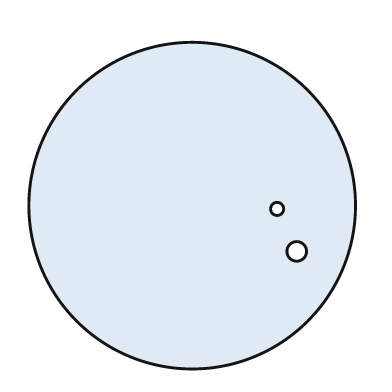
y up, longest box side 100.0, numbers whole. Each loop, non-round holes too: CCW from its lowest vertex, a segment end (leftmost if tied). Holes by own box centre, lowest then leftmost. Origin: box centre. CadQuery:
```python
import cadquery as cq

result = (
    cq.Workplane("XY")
    .moveTo(0.0, 0.0)
    .circle(50.0)
    .moveTo(32.0, -14.0)
    .circle(3.0)
    .moveTo(26.0, -1.0)
    .circle(2.0)
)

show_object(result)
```